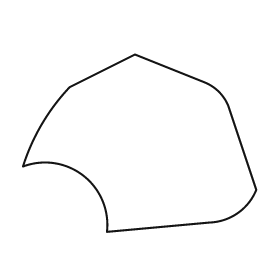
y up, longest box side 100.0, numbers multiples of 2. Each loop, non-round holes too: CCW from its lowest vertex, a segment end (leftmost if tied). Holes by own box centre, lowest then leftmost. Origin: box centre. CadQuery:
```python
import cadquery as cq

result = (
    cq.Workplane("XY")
    .moveTo(-14.0, -38.0)
    .lineTo(30.0, -34.0)
    .threePointArc((42.0, -30.0), (50.0, -20.0))
    .lineTo(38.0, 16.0)
    .threePointArc((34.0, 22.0), (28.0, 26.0))
    .lineTo(-2.0, 38.0)
    .lineTo(-30.0, 24.0)
    .threePointArc((-42.0, 8.0), (-50.0, -10.0))
    .threePointArc((-24.0, -14.0), (-14.0, -38.0))
    .close()
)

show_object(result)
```